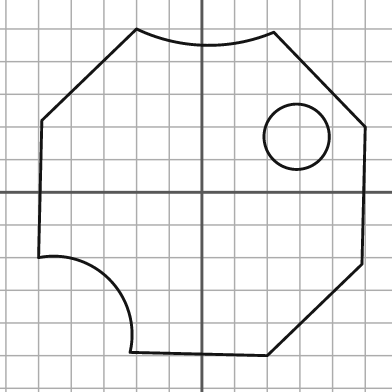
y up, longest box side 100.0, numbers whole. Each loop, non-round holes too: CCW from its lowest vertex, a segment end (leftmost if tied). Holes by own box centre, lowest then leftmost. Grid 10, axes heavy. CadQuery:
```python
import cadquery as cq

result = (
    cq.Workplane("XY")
    .moveTo(20.0, -50.0)
    .lineTo(49.0, -22.0)
    .lineTo(50.0, 20.0)
    .lineTo(22.0, 49.0)
    .threePointArc((1.0, 45.0), (-20.0, 50.0))
    .lineTo(-49.0, 22.0)
    .lineTo(-50.0, -20.0)
    .threePointArc((-28.0, -27.0), (-22.0, -49.0))
    .close()
    .moveTo(29.0, 17.0)
    .circle(10.0)
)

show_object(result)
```